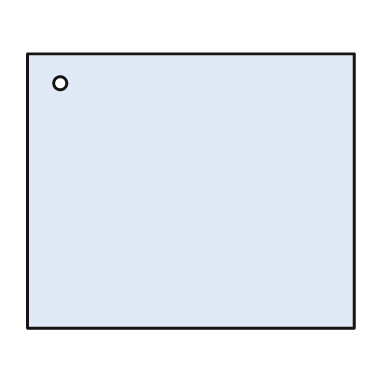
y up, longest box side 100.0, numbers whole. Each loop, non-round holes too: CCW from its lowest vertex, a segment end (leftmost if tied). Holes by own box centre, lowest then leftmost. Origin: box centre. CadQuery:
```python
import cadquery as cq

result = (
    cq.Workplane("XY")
    .moveTo(-50.0, -42.0)
    .lineTo(50.0, -42.0)
    .lineTo(50.0, 42.0)
    .lineTo(-50.0, 42.0)
    .close()
    .moveTo(-40.0, 33.0)
    .circle(2.0)
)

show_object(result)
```